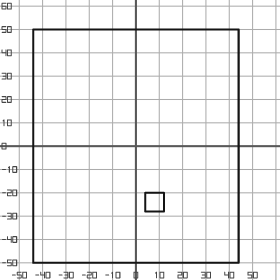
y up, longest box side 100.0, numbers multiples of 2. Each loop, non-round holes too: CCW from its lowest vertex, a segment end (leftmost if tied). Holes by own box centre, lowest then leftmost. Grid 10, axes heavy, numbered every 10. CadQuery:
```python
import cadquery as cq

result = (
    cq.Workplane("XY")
    .moveTo(-44.0, -50.0)
    .lineTo(44.0, -50.0)
    .lineTo(44.0, 50.0)
    .lineTo(-44.0, 50.0)
    .close()
    .moveTo(4.0, -28.0)
    .lineTo(12.0, -28.0)
    .lineTo(12.0, -20.0)
    .lineTo(4.0, -20.0)
    .close()
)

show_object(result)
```